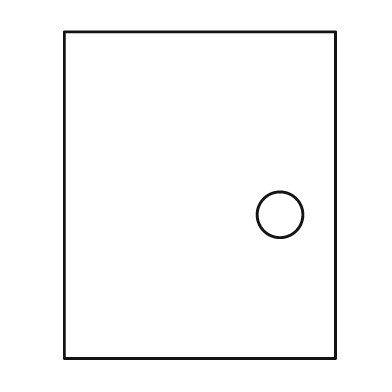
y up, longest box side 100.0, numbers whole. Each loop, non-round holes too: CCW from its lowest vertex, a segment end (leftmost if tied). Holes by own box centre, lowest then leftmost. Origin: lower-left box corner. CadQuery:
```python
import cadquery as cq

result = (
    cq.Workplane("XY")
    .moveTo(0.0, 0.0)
    .lineTo(83.0, 0.0)
    .lineTo(83.0, 100.0)
    .lineTo(0.0, 100.0)
    .close()
    .moveTo(66.0, 44.0)
    .circle(7.0)
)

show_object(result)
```